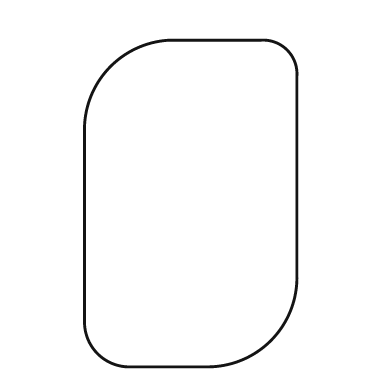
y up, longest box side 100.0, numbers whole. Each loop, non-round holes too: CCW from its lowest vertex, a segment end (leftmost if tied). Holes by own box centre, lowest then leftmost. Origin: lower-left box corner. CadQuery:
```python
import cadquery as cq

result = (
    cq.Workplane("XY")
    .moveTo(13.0, 0.0)
    .lineTo(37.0, 0.0)
    .threePointArc((57.0, 8.0), (65.0, 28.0))
    .lineTo(65.0, 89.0)
    .threePointArc((62.0, 97.0), (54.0, 100.0))
    .lineTo(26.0, 100.0)
    .threePointArc((8.0, 92.0), (0.0, 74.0))
    .lineTo(0.0, 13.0)
    .threePointArc((4.0, 4.0), (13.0, 0.0))
    .close()
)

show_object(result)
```